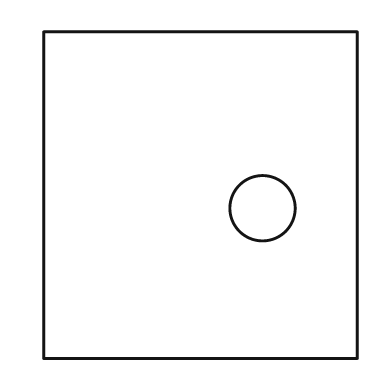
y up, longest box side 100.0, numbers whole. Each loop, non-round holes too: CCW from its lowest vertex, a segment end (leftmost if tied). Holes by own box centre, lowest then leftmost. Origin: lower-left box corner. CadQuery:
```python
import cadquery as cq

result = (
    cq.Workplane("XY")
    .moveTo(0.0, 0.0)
    .lineTo(96.0, 0.0)
    .lineTo(96.0, 100.0)
    .lineTo(0.0, 100.0)
    .close()
    .moveTo(67.0, 46.0)
    .circle(10.0)
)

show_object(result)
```